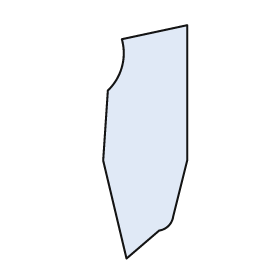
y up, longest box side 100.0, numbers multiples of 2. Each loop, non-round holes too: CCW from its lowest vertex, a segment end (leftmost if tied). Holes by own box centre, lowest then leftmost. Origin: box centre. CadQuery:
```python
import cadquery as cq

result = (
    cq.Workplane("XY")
    .moveTo(-8.0, -50.0)
    .lineTo(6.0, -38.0)
    .threePointArc((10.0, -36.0), (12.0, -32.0))
    .lineTo(18.0, -8.0)
    .lineTo(18.0, 50.0)
    .lineTo(-10.0, 44.0)
    .threePointArc((-10.0, 32.0), (-16.0, 22.0))
    .lineTo(-18.0, -8.0)
    .close()
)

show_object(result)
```